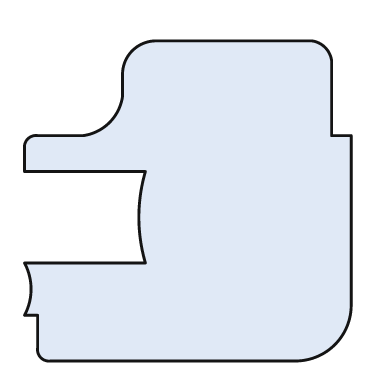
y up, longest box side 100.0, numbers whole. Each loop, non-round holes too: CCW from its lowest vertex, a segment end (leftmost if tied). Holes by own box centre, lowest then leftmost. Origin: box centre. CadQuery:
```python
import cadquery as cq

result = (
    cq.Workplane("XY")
    .moveTo(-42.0, -49.0)
    .lineTo(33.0, -49.0)
    .threePointArc((45.0, -44.0), (50.0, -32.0))
    .lineTo(50.0, 20.0)
    .lineTo(44.0, 20.0)
    .lineTo(44.0, 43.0)
    .threePointArc((42.0, 47.0), (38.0, 49.0))
    .lineTo(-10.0, 49.0)
    .threePointArc((-17.0, 46.0), (-20.0, 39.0))
    .lineTo(-20.0, 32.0)
    .threePointArc((-24.0, 24.0), (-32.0, 20.0))
    .lineTo(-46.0, 20.0)
    .threePointArc((-49.0, 19.0), (-50.0, 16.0))
    .lineTo(-50.0, 9.0)
    .lineTo(-13.0, 9.0)
    .threePointArc((-15.0, -5.0), (-13.0, -19.0))
    .lineTo(-50.0, -19.0)
    .threePointArc((-48.0, -27.0), (-50.0, -35.0))
    .lineTo(-46.0, -35.0)
    .lineTo(-46.0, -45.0)
    .threePointArc((-45.0, -48.0), (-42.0, -49.0))
    .close()
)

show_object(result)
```